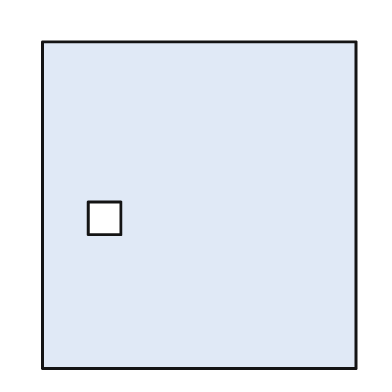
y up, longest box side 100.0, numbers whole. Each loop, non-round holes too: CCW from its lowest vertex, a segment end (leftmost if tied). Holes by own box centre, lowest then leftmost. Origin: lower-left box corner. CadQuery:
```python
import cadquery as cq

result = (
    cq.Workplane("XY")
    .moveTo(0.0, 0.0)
    .lineTo(96.0, 0.0)
    .lineTo(96.0, 100.0)
    .lineTo(0.0, 100.0)
    .close()
    .moveTo(14.0, 41.0)
    .lineTo(24.0, 41.0)
    .lineTo(24.0, 51.0)
    .lineTo(14.0, 51.0)
    .close()
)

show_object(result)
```